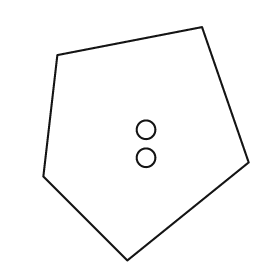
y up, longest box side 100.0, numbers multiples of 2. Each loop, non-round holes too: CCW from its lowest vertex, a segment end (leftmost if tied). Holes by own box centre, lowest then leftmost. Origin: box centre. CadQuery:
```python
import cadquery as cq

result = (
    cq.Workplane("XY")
    .moveTo(-8.0, -50.0)
    .lineTo(44.0, -8.0)
    .lineTo(24.0, 50.0)
    .lineTo(-38.0, 38.0)
    .lineTo(-44.0, -14.0)
    .close()
    .moveTo(0.0, -6.0)
    .circle(4.0)
    .moveTo(0.0, 6.0)
    .circle(4.0)
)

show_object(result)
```